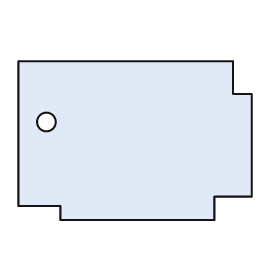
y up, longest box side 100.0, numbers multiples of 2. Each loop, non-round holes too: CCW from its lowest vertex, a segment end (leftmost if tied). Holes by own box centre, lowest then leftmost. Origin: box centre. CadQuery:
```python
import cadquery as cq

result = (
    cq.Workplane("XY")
    .moveTo(-32.0, -34.0)
    .lineTo(34.0, -34.0)
    .lineTo(34.0, -24.0)
    .lineTo(50.0, -24.0)
    .lineTo(50.0, 20.0)
    .lineTo(42.0, 20.0)
    .lineTo(42.0, 34.0)
    .lineTo(-50.0, 34.0)
    .lineTo(-50.0, -28.0)
    .lineTo(-32.0, -28.0)
    .close()
    .moveTo(-38.0, 8.0)
    .circle(4.0)
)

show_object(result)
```